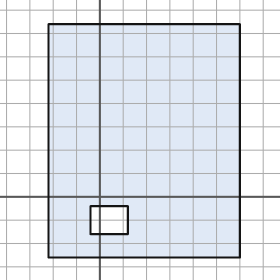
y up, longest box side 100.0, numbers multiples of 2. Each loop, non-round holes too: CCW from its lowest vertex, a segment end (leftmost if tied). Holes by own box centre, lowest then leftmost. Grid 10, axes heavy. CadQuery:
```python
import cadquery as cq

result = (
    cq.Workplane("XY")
    .moveTo(-22.0, -26.0)
    .lineTo(60.0, -26.0)
    .lineTo(60.0, 74.0)
    .lineTo(-22.0, 74.0)
    .close()
    .moveTo(-4.0, -16.0)
    .lineTo(12.0, -16.0)
    .lineTo(12.0, -4.0)
    .lineTo(-4.0, -4.0)
    .close()
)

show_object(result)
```